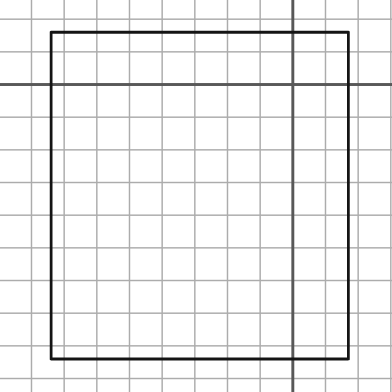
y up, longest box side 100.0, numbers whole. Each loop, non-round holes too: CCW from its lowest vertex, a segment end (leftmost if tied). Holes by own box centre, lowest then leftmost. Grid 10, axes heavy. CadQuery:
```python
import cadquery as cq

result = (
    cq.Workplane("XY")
    .moveTo(-74.0, -84.0)
    .lineTo(17.0, -84.0)
    .lineTo(17.0, 16.0)
    .lineTo(-74.0, 16.0)
    .close()
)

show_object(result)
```